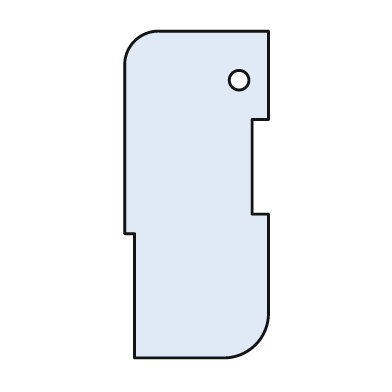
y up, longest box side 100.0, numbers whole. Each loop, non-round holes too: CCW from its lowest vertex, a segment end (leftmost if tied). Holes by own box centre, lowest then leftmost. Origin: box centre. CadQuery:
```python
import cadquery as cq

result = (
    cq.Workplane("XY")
    .moveTo(-19.0, -50.0)
    .lineTo(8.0, -50.0)
    .threePointArc((18.0, -46.0), (22.0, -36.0))
    .lineTo(22.0, -6.0)
    .lineTo(17.0, -6.0)
    .lineTo(17.0, 23.0)
    .lineTo(22.0, 23.0)
    .lineTo(22.0, 50.0)
    .lineTo(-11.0, 50.0)
    .threePointArc((-19.0, 47.0), (-22.0, 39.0))
    .lineTo(-22.0, -12.0)
    .lineTo(-19.0, -12.0)
    .close()
    .moveTo(13.0, 35.0)
    .circle(3.0)
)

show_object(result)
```